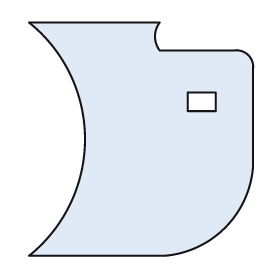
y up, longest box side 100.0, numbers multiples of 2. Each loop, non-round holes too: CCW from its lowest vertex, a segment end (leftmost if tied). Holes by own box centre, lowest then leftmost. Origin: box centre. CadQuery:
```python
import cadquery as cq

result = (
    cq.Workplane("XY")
    .moveTo(-48.0, -50.0)
    .lineTo(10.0, -50.0)
    .threePointArc((36.0, -38.0), (48.0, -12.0))
    .lineTo(48.0, 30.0)
    .threePointArc((46.0, 36.0), (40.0, 38.0))
    .lineTo(8.0, 38.0)
    .threePointArc((6.0, 44.0), (8.0, 50.0))
    .lineTo(-48.0, 50.0)
    .threePointArc((-24.0, 0.0), (-48.0, -50.0))
    .close()
    .moveTo(20.0, 12.0)
    .lineTo(32.0, 12.0)
    .lineTo(32.0, 20.0)
    .lineTo(20.0, 20.0)
    .close()
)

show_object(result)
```